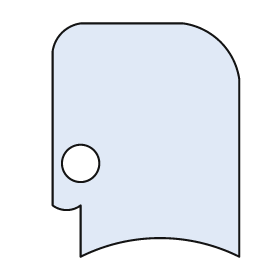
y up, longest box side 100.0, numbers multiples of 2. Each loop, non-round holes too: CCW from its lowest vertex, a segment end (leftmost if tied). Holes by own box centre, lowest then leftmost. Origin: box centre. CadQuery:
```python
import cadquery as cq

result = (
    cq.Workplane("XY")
    .moveTo(-28.0, -50.0)
    .threePointArc((6.0, -42.0), (40.0, -50.0))
    .lineTo(40.0, 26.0)
    .threePointArc((32.0, 42.0), (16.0, 50.0))
    .lineTo(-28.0, 50.0)
    .threePointArc((-36.0, 46.0), (-40.0, 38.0))
    .lineTo(-40.0, -28.0)
    .threePointArc((-34.0, -30.0), (-28.0, -28.0))
    .close()
    .moveTo(-28.0, -10.0)
    .circle(8.0)
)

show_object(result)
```